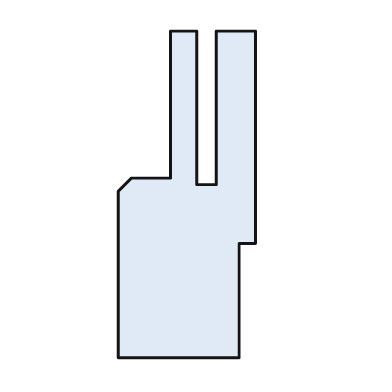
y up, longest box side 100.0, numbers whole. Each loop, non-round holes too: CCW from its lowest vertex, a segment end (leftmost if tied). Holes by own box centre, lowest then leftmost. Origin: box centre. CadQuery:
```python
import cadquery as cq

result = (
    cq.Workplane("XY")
    .moveTo(-21.0, -50.0)
    .lineTo(16.0, -50.0)
    .lineTo(16.0, -15.0)
    .lineTo(21.0, -15.0)
    .lineTo(21.0, 50.0)
    .lineTo(9.0, 50.0)
    .lineTo(9.0, 3.0)
    .lineTo(3.0, 3.0)
    .lineTo(3.0, 50.0)
    .lineTo(-5.0, 50.0)
    .lineTo(-5.0, 5.0)
    .lineTo(-17.0, 5.0)
    .lineTo(-21.0, 1.0)
    .close()
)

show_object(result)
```